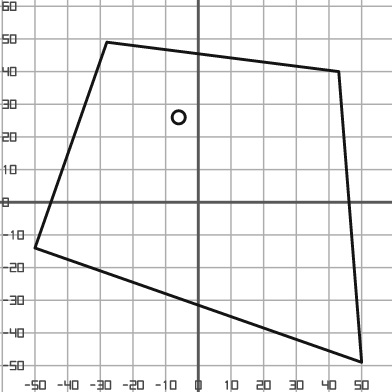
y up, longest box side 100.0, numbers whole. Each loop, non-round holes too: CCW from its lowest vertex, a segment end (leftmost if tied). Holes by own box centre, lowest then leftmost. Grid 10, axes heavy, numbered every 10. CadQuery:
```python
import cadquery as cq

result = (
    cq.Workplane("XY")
    .moveTo(50.0, -49.0)
    .lineTo(43.0, 40.0)
    .lineTo(-28.0, 49.0)
    .lineTo(-50.0, -14.0)
    .close()
    .moveTo(-6.0, 26.0)
    .circle(2.0)
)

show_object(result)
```